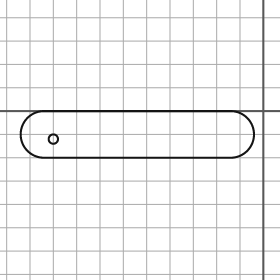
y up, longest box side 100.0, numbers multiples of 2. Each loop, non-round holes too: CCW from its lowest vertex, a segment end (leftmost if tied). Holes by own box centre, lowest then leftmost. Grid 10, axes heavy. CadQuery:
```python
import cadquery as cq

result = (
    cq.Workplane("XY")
    .moveTo(-94.0, -20.0)
    .lineTo(-14.0, -20.0)
    .threePointArc((-4.0, -10.0), (-14.0, 0.0))
    .lineTo(-94.0, 0.0)
    .threePointArc((-104.0, -10.0), (-94.0, -20.0))
    .close()
    .moveTo(-90.0, -12.0)
    .circle(2.0)
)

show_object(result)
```